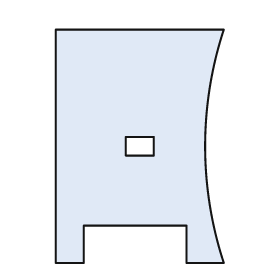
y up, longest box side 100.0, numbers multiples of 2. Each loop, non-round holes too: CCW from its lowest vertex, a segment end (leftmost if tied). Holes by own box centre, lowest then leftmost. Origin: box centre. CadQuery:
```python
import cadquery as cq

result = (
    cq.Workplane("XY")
    .moveTo(-36.0, -50.0)
    .lineTo(-24.0, -50.0)
    .lineTo(-24.0, -34.0)
    .lineTo(20.0, -34.0)
    .lineTo(20.0, -50.0)
    .lineTo(36.0, -50.0)
    .threePointArc((28.0, 0.0), (36.0, 50.0))
    .lineTo(-36.0, 50.0)
    .close()
    .moveTo(-6.0, -4.0)
    .lineTo(6.0, -4.0)
    .lineTo(6.0, 4.0)
    .lineTo(-6.0, 4.0)
    .close()
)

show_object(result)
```